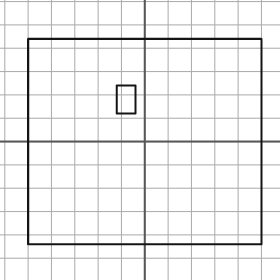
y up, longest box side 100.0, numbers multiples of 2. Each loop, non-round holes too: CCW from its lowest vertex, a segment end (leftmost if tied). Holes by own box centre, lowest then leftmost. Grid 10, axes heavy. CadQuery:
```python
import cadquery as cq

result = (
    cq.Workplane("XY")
    .moveTo(-50.0, -44.0)
    .lineTo(50.0, -44.0)
    .lineTo(50.0, 44.0)
    .lineTo(-50.0, 44.0)
    .close()
    .moveTo(-12.0, 12.0)
    .lineTo(-4.0, 12.0)
    .lineTo(-4.0, 24.0)
    .lineTo(-12.0, 24.0)
    .close()
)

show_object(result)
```